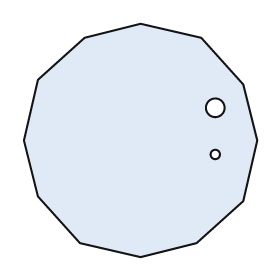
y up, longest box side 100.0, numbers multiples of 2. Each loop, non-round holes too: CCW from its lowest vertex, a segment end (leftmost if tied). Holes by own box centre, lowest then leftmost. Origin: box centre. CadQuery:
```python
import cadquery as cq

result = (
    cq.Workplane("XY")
    .moveTo(0.0, -50.0)
    .lineTo(24.0, -44.0)
    .lineTo(44.0, -26.0)
    .lineTo(50.0, 0.0)
    .lineTo(44.0, 24.0)
    .lineTo(26.0, 44.0)
    .lineTo(0.0, 50.0)
    .lineTo(-24.0, 44.0)
    .lineTo(-44.0, 26.0)
    .lineTo(-50.0, 0.0)
    .lineTo(-44.0, -24.0)
    .lineTo(-26.0, -44.0)
    .close()
    .moveTo(32.0, -6.0)
    .circle(2.0)
    .moveTo(32.0, 14.0)
    .circle(4.0)
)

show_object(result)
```